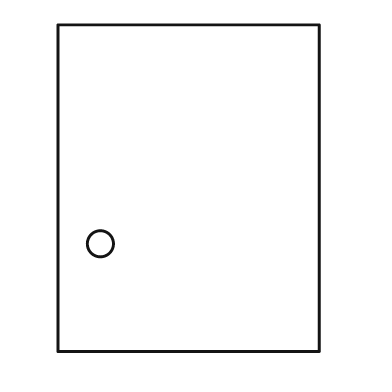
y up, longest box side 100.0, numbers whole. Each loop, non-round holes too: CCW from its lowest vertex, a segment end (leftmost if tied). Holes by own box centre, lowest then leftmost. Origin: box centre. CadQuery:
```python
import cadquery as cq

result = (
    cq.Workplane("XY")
    .moveTo(-40.0, -50.0)
    .lineTo(40.0, -50.0)
    .lineTo(40.0, 50.0)
    .lineTo(-40.0, 50.0)
    .close()
    .moveTo(-27.0, -17.0)
    .circle(4.0)
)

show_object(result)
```